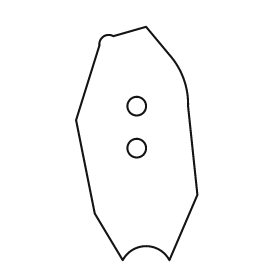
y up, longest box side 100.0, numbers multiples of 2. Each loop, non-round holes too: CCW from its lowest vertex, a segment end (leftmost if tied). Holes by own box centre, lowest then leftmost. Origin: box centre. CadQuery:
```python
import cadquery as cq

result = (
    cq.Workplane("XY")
    .moveTo(-6.0, -50.0)
    .threePointArc((4.0, -44.0), (14.0, -50.0))
    .lineTo(26.0, -22.0)
    .lineTo(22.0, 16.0)
    .threePointArc((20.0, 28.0), (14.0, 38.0))
    .lineTo(4.0, 50.0)
    .lineTo(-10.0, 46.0)
    .threePointArc((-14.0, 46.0), (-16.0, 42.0))
    .lineTo(-26.0, 10.0)
    .lineTo(-18.0, -30.0)
    .close()
    .moveTo(0.0, -2.0)
    .circle(4.0)
    .moveTo(0.0, 16.0)
    .circle(4.0)
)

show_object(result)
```